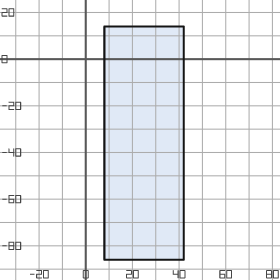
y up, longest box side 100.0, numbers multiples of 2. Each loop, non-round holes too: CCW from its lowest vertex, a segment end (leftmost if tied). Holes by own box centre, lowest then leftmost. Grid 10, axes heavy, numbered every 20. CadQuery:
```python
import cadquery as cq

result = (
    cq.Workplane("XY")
    .moveTo(8.0, -86.0)
    .lineTo(42.0, -86.0)
    .lineTo(42.0, 14.0)
    .lineTo(8.0, 14.0)
    .close()
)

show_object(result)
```